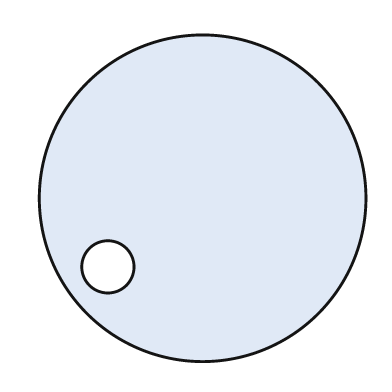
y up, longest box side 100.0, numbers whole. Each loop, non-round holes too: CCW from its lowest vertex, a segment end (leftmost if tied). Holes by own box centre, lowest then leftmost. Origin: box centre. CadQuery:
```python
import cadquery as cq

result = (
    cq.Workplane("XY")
    .moveTo(0.0, 0.0)
    .circle(50.0)
    .moveTo(-29.0, -21.0)
    .circle(8.0)
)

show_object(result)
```